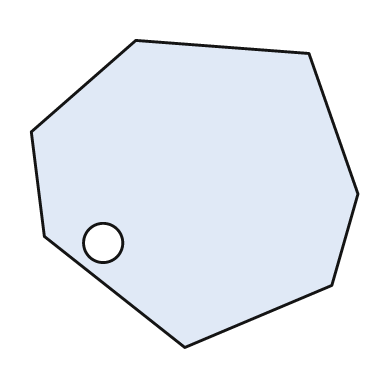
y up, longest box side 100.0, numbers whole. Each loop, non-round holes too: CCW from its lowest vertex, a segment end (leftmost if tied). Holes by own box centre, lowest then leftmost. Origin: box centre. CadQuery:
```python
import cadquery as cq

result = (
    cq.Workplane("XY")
    .moveTo(-3.0, -47.0)
    .lineTo(42.0, -28.0)
    .lineTo(50.0, 0.0)
    .lineTo(35.0, 43.0)
    .lineTo(-18.0, 47.0)
    .lineTo(-50.0, 19.0)
    .lineTo(-46.0, -13.0)
    .close()
    .moveTo(-28.0, -15.0)
    .circle(6.0)
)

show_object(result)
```